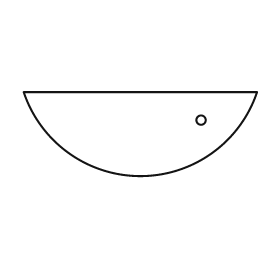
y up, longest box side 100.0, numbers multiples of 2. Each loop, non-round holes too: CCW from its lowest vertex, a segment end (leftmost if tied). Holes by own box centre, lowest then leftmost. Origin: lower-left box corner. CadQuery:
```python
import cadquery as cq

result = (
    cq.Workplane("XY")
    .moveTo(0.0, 36.0)
    .threePointArc((50.0, 0.0), (100.0, 36.0))
    .close()
    .moveTo(76.0, 24.0)
    .circle(2.0)
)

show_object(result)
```